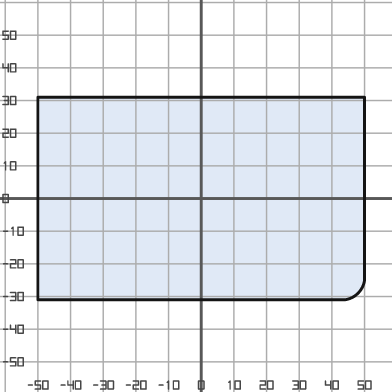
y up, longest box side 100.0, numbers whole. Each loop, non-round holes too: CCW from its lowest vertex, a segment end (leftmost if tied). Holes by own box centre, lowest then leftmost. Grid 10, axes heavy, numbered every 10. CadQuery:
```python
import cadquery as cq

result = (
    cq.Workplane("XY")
    .moveTo(-50.0, -31.0)
    .lineTo(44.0, -31.0)
    .threePointArc((48.0, -29.0), (50.0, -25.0))
    .lineTo(50.0, 31.0)
    .lineTo(-50.0, 31.0)
    .close()
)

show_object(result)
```